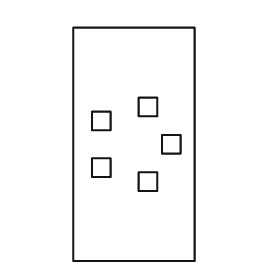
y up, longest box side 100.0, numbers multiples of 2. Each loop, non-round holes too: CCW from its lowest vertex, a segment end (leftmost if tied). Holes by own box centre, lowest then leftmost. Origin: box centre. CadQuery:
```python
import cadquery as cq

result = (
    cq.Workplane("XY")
    .moveTo(-26.0, -50.0)
    .lineTo(26.0, -50.0)
    .lineTo(26.0, 50.0)
    .lineTo(-26.0, 50.0)
    .close()
    .moveTo(2.0, -20.0)
    .lineTo(10.0, -20.0)
    .lineTo(10.0, -12.0)
    .lineTo(2.0, -12.0)
    .close()
    .moveTo(-18.0, -14.0)
    .lineTo(-10.0, -14.0)
    .lineTo(-10.0, -6.0)
    .lineTo(-18.0, -6.0)
    .close()
    .moveTo(12.0, -4.0)
    .lineTo(20.0, -4.0)
    .lineTo(20.0, 4.0)
    .lineTo(12.0, 4.0)
    .close()
    .moveTo(-18.0, 6.0)
    .lineTo(-10.0, 6.0)
    .lineTo(-10.0, 14.0)
    .lineTo(-18.0, 14.0)
    .close()
    .moveTo(2.0, 12.0)
    .lineTo(10.0, 12.0)
    .lineTo(10.0, 20.0)
    .lineTo(2.0, 20.0)
    .close()
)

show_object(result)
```